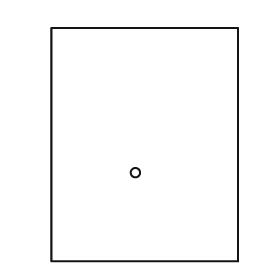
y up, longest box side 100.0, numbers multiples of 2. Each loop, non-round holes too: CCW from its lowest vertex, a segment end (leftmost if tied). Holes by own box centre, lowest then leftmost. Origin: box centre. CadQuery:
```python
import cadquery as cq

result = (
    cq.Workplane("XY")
    .moveTo(-40.0, -50.0)
    .lineTo(40.0, -50.0)
    .lineTo(40.0, 50.0)
    .lineTo(-40.0, 50.0)
    .close()
    .moveTo(-4.0, -12.0)
    .circle(2.0)
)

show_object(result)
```